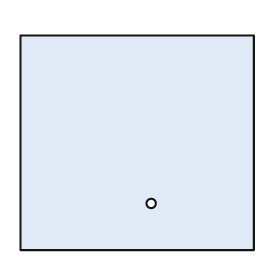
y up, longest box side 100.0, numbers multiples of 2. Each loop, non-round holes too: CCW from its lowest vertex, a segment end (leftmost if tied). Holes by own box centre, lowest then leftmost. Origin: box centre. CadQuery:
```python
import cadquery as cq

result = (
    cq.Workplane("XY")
    .moveTo(-50.0, -46.0)
    .lineTo(50.0, -46.0)
    .lineTo(50.0, 46.0)
    .lineTo(-50.0, 46.0)
    .close()
    .moveTo(6.0, -26.0)
    .circle(2.0)
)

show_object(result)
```